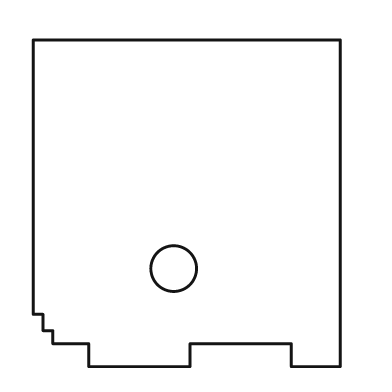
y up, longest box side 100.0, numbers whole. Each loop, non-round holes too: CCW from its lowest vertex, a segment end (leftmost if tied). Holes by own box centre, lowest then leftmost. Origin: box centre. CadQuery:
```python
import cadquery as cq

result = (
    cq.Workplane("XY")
    .moveTo(-30.0, -50.0)
    .lineTo(1.0, -50.0)
    .lineTo(1.0, -43.0)
    .lineTo(32.0, -43.0)
    .lineTo(32.0, -50.0)
    .lineTo(47.0, -50.0)
    .lineTo(47.0, 50.0)
    .lineTo(-47.0, 50.0)
    .lineTo(-47.0, -34.0)
    .lineTo(-44.0, -34.0)
    .lineTo(-44.0, -39.0)
    .lineTo(-41.0, -39.0)
    .lineTo(-41.0, -43.0)
    .lineTo(-30.0, -43.0)
    .close()
    .moveTo(-4.0, -20.0)
    .circle(7.0)
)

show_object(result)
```